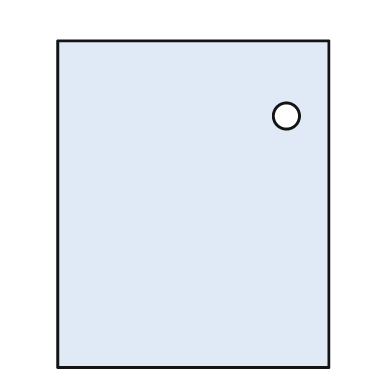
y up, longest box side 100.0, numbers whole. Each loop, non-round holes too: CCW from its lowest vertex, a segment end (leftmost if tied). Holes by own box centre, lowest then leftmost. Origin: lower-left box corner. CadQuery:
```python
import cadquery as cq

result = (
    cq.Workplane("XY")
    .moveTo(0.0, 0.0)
    .lineTo(83.0, 0.0)
    .lineTo(83.0, 100.0)
    .lineTo(0.0, 100.0)
    .close()
    .moveTo(70.0, 77.0)
    .circle(4.0)
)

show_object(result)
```